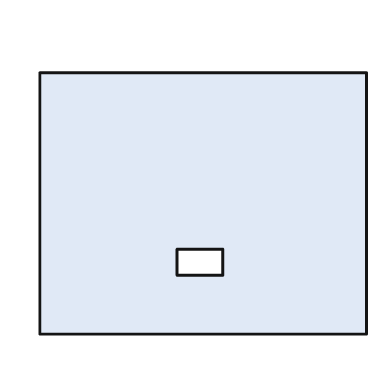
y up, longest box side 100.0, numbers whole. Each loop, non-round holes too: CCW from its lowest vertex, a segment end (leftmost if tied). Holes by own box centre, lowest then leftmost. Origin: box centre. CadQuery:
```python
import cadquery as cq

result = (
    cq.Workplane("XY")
    .moveTo(-50.0, -40.0)
    .lineTo(50.0, -40.0)
    .lineTo(50.0, 40.0)
    .lineTo(-50.0, 40.0)
    .close()
    .moveTo(-8.0, -22.0)
    .lineTo(6.0, -22.0)
    .lineTo(6.0, -14.0)
    .lineTo(-8.0, -14.0)
    .close()
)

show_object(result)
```